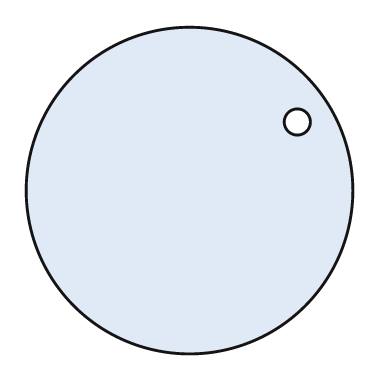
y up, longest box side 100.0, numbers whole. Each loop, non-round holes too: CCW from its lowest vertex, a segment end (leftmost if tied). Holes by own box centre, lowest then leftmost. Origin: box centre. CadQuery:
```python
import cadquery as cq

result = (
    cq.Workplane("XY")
    .moveTo(0.0, 0.0)
    .circle(50.0)
    .moveTo(33.0, 21.0)
    .circle(4.0)
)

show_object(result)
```